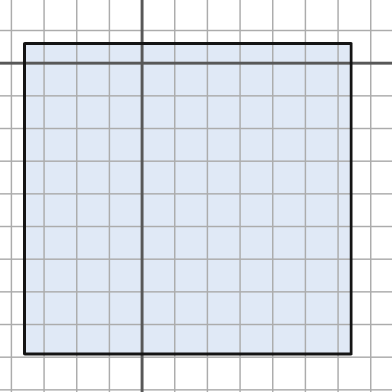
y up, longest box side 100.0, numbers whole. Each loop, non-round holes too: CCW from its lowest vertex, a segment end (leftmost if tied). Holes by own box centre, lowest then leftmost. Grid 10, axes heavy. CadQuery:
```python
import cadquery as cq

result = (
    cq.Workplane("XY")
    .moveTo(-36.0, -89.0)
    .lineTo(64.0, -89.0)
    .lineTo(64.0, 6.0)
    .lineTo(-36.0, 6.0)
    .close()
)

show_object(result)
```